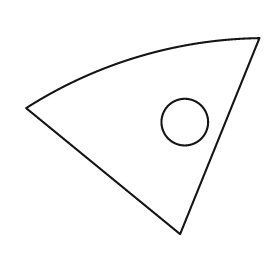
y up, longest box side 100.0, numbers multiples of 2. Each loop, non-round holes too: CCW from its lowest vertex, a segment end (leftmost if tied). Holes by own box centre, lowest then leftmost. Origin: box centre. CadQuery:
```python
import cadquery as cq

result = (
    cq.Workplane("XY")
    .moveTo(16.0, -42.0)
    .lineTo(50.0, 42.0)
    .threePointArc((-2.0, 34.0), (-50.0, 12.0))
    .close()
    .moveTo(18.0, 6.0)
    .circle(10.0)
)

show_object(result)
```